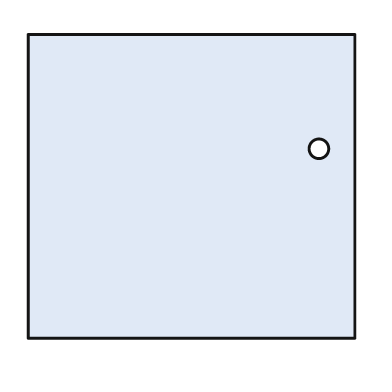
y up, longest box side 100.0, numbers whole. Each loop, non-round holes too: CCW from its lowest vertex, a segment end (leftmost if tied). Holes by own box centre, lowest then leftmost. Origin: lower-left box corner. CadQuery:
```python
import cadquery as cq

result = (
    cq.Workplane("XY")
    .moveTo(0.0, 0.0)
    .lineTo(100.0, 0.0)
    .lineTo(100.0, 93.0)
    .lineTo(0.0, 93.0)
    .close()
    .moveTo(89.0, 58.0)
    .circle(3.0)
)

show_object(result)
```